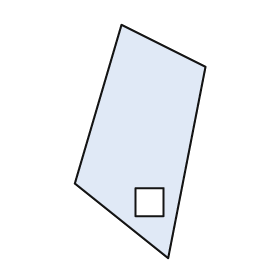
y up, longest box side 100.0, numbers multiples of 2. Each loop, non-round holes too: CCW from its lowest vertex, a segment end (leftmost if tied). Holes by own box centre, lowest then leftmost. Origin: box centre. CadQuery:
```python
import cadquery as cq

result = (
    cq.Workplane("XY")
    .moveTo(12.0, -50.0)
    .lineTo(28.0, 32.0)
    .lineTo(-8.0, 50.0)
    .lineTo(-28.0, -18.0)
    .close()
    .moveTo(-2.0, -32.0)
    .lineTo(10.0, -32.0)
    .lineTo(10.0, -20.0)
    .lineTo(-2.0, -20.0)
    .close()
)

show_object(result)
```